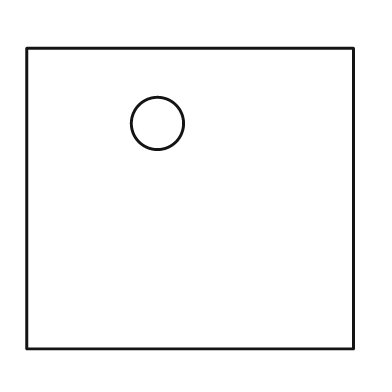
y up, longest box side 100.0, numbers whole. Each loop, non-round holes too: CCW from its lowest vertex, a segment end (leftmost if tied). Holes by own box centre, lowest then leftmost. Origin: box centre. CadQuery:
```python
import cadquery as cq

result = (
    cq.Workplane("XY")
    .moveTo(-50.0, -46.0)
    .lineTo(50.0, -46.0)
    .lineTo(50.0, 46.0)
    .lineTo(-50.0, 46.0)
    .close()
    .moveTo(-10.0, 23.0)
    .circle(8.0)
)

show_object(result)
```